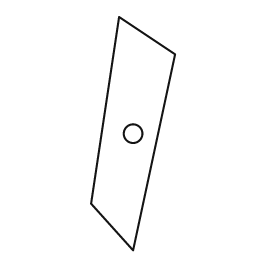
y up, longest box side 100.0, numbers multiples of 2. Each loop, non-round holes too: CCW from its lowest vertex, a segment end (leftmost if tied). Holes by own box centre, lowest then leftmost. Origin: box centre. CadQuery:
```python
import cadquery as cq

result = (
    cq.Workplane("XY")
    .moveTo(0.0, -50.0)
    .lineTo(18.0, 34.0)
    .lineTo(-6.0, 50.0)
    .lineTo(-18.0, -30.0)
    .close()
    .moveTo(0.0, 0.0)
    .circle(4.0)
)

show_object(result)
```